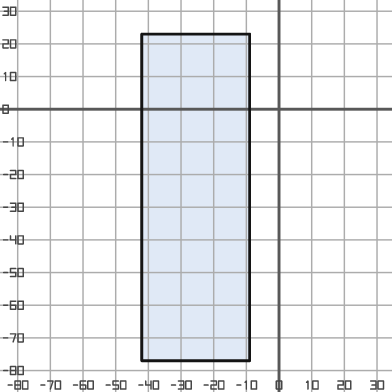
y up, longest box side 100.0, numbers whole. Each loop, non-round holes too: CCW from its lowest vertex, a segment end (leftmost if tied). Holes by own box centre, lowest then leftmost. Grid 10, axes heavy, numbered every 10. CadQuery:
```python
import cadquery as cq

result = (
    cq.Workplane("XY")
    .moveTo(-42.0, -77.0)
    .lineTo(-9.0, -77.0)
    .lineTo(-9.0, 23.0)
    .lineTo(-42.0, 23.0)
    .close()
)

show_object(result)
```